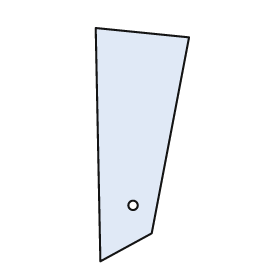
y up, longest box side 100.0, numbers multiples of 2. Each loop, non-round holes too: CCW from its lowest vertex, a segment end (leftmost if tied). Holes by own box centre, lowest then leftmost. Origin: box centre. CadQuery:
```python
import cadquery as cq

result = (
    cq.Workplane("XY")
    .moveTo(-18.0, -50.0)
    .lineTo(4.0, -38.0)
    .lineTo(20.0, 46.0)
    .lineTo(-20.0, 50.0)
    .close()
    .moveTo(-4.0, -26.0)
    .circle(2.0)
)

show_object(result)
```